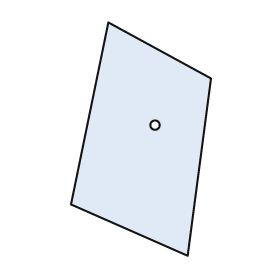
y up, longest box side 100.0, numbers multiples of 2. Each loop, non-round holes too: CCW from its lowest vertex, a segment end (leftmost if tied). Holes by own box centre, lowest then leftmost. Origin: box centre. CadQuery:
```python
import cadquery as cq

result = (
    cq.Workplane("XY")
    .moveTo(20.0, -50.0)
    .lineTo(30.0, 26.0)
    .lineTo(-14.0, 50.0)
    .lineTo(-30.0, -28.0)
    .close()
    .moveTo(6.0, 6.0)
    .circle(2.0)
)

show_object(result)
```